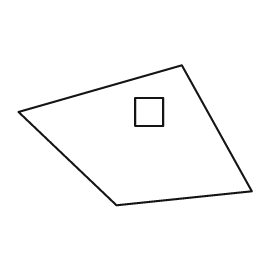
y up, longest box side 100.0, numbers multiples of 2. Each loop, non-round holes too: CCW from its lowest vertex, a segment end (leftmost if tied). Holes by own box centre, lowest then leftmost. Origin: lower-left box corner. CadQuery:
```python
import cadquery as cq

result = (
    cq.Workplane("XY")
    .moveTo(42.0, 0.0)
    .lineTo(100.0, 6.0)
    .lineTo(70.0, 60.0)
    .lineTo(0.0, 40.0)
    .close()
    .moveTo(50.0, 34.0)
    .lineTo(62.0, 34.0)
    .lineTo(62.0, 46.0)
    .lineTo(50.0, 46.0)
    .close()
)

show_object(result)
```